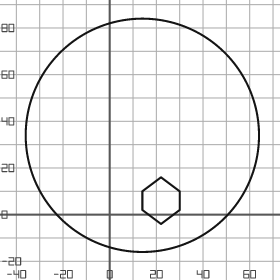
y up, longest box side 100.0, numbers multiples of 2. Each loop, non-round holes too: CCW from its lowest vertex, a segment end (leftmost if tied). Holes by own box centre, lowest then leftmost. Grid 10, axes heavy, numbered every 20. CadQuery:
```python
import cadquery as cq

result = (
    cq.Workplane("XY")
    .moveTo(14.0, 34.0)
    .circle(50.0)
    .moveTo(22.0, -4.0)
    .lineTo(30.0, 2.0)
    .lineTo(30.0, 10.0)
    .lineTo(22.0, 16.0)
    .lineTo(14.0, 10.0)
    .lineTo(14.0, 2.0)
    .close()
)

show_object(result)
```